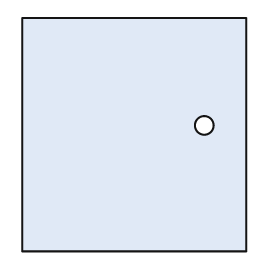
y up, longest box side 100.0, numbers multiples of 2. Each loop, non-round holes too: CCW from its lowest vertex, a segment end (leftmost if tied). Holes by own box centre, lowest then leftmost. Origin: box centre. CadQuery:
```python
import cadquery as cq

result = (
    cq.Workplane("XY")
    .moveTo(-48.0, -50.0)
    .lineTo(48.0, -50.0)
    .lineTo(48.0, 50.0)
    .lineTo(-48.0, 50.0)
    .close()
    .moveTo(30.0, 4.0)
    .circle(4.0)
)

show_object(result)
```